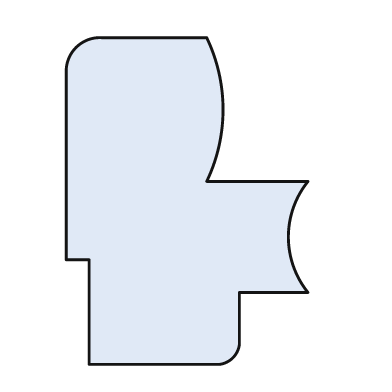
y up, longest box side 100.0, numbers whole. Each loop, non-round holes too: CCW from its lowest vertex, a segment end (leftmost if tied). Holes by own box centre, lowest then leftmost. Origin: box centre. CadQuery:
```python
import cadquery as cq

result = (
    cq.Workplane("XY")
    .moveTo(-30.0, -50.0)
    .lineTo(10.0, -50.0)
    .threePointArc((14.0, -48.0), (16.0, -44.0))
    .lineTo(16.0, -28.0)
    .lineTo(37.0, -28.0)
    .threePointArc((31.0, -11.0), (37.0, 6.0))
    .lineTo(6.0, 6.0)
    .threePointArc((11.0, 28.0), (6.0, 50.0))
    .lineTo(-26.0, 50.0)
    .threePointArc((-34.0, 47.0), (-37.0, 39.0))
    .lineTo(-37.0, -18.0)
    .lineTo(-30.0, -18.0)
    .close()
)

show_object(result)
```